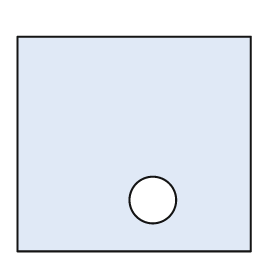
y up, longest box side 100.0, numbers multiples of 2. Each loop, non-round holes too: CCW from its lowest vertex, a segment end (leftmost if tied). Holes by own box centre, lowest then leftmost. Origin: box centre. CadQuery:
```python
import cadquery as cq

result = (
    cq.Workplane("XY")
    .moveTo(-50.0, -46.0)
    .lineTo(50.0, -46.0)
    .lineTo(50.0, 46.0)
    .lineTo(-50.0, 46.0)
    .close()
    .moveTo(8.0, -24.0)
    .circle(10.0)
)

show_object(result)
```